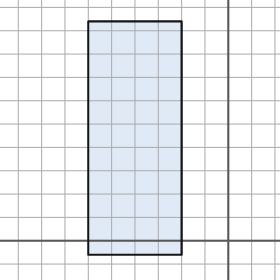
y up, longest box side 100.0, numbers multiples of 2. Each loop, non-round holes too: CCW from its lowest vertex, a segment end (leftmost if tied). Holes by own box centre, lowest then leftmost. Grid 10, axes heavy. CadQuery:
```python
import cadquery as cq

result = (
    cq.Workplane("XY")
    .moveTo(-60.0, -6.0)
    .lineTo(-20.0, -6.0)
    .lineTo(-20.0, 94.0)
    .lineTo(-60.0, 94.0)
    .close()
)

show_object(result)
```